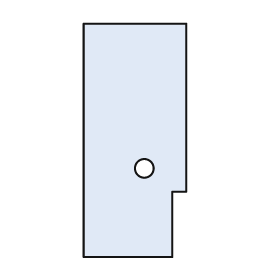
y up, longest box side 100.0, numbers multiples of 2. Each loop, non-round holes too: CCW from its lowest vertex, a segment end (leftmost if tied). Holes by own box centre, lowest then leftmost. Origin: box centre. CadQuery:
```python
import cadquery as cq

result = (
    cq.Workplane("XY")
    .moveTo(-22.0, -50.0)
    .lineTo(16.0, -50.0)
    .lineTo(16.0, -22.0)
    .lineTo(22.0, -22.0)
    .lineTo(22.0, 50.0)
    .lineTo(-22.0, 50.0)
    .close()
    .moveTo(4.0, -12.0)
    .circle(4.0)
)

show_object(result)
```